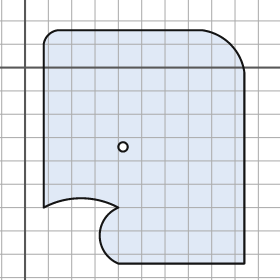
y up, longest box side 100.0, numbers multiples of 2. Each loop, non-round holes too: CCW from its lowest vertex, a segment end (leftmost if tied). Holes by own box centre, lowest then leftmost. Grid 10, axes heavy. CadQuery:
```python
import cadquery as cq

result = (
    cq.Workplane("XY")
    .moveTo(40.0, -84.0)
    .lineTo(94.0, -84.0)
    .lineTo(94.0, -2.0)
    .threePointArc((88.0, 10.0), (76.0, 16.0))
    .lineTo(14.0, 16.0)
    .threePointArc((10.0, 14.0), (8.0, 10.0))
    .lineTo(8.0, -60.0)
    .threePointArc((24.0, -56.0), (40.0, -60.0))
    .threePointArc((32.0, -72.0), (40.0, -84.0))
    .close()
    .moveTo(42.0, -34.0)
    .circle(2.0)
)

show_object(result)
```